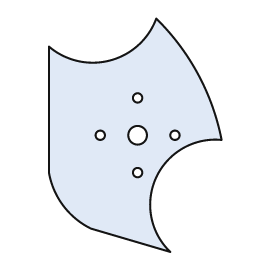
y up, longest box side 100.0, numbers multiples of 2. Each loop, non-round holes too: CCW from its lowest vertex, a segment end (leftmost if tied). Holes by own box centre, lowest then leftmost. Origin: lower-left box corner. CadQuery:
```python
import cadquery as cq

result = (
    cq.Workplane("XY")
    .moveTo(52.0, 0.0)
    .threePointArc((46.0, 32.0), (74.0, 48.0))
    .threePointArc((64.0, 76.0), (46.0, 100.0))
    .threePointArc((26.0, 82.0), (0.0, 88.0))
    .lineTo(0.0, 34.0)
    .threePointArc((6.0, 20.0), (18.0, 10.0))
    .close()
    .moveTo(38.0, 34.0)
    .circle(2.0)
    .moveTo(22.0, 50.0)
    .circle(2.0)
    .moveTo(38.0, 50.0)
    .circle(4.0)
    .moveTo(54.0, 50.0)
    .circle(2.0)
    .moveTo(38.0, 66.0)
    .circle(2.0)
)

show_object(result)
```